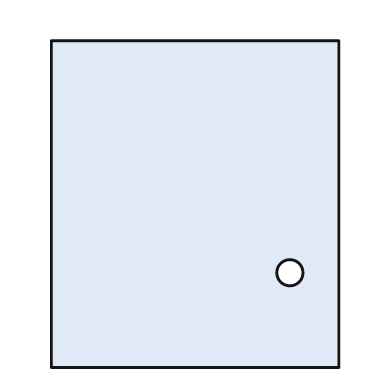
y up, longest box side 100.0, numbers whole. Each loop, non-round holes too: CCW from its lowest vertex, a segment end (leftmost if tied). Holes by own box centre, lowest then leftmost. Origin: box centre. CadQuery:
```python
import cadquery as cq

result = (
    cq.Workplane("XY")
    .moveTo(-44.0, -50.0)
    .lineTo(44.0, -50.0)
    .lineTo(44.0, 50.0)
    .lineTo(-44.0, 50.0)
    .close()
    .moveTo(29.0, -21.0)
    .circle(4.0)
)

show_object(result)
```